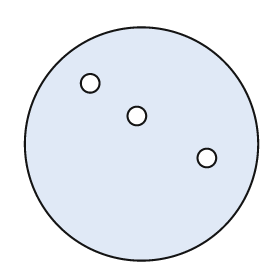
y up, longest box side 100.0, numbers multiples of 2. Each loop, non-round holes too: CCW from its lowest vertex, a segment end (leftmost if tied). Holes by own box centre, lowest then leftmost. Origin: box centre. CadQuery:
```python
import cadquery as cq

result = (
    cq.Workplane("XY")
    .moveTo(0.0, 0.0)
    .circle(50.0)
    .moveTo(28.0, -6.0)
    .circle(4.0)
    .moveTo(-2.0, 12.0)
    .circle(4.0)
    .moveTo(-22.0, 26.0)
    .circle(4.0)
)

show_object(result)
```